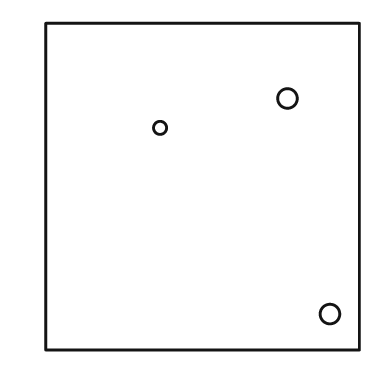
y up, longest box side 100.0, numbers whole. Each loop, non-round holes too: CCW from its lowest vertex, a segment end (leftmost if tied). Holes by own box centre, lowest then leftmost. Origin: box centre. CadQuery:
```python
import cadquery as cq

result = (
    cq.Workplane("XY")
    .moveTo(-48.0, -50.0)
    .lineTo(48.0, -50.0)
    .lineTo(48.0, 50.0)
    .lineTo(-48.0, 50.0)
    .close()
    .moveTo(39.0, -39.0)
    .circle(3.0)
    .moveTo(-13.0, 18.0)
    .circle(2.0)
    .moveTo(26.0, 27.0)
    .circle(3.0)
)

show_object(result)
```